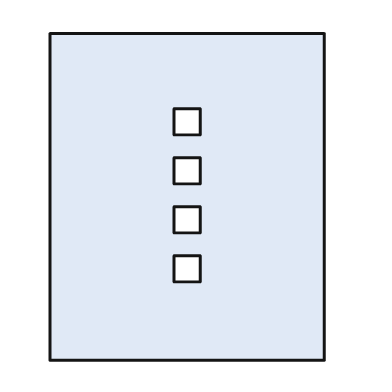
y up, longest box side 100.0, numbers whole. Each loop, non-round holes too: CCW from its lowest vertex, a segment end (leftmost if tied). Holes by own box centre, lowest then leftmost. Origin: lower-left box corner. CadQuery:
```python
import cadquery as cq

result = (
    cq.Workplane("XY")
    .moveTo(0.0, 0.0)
    .lineTo(84.0, 0.0)
    .lineTo(84.0, 100.0)
    .lineTo(0.0, 100.0)
    .close()
    .moveTo(38.0, 24.0)
    .lineTo(46.0, 24.0)
    .lineTo(46.0, 32.0)
    .lineTo(38.0, 32.0)
    .close()
    .moveTo(38.0, 39.0)
    .lineTo(46.0, 39.0)
    .lineTo(46.0, 47.0)
    .lineTo(38.0, 47.0)
    .close()
    .moveTo(38.0, 54.0)
    .lineTo(46.0, 54.0)
    .lineTo(46.0, 62.0)
    .lineTo(38.0, 62.0)
    .close()
    .moveTo(38.0, 69.0)
    .lineTo(46.0, 69.0)
    .lineTo(46.0, 77.0)
    .lineTo(38.0, 77.0)
    .close()
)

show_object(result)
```